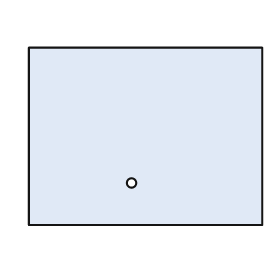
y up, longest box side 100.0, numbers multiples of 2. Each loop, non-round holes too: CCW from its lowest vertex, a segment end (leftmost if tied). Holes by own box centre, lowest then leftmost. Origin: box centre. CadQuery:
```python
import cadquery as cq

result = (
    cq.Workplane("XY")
    .moveTo(-50.0, -38.0)
    .lineTo(50.0, -38.0)
    .lineTo(50.0, 38.0)
    .lineTo(-50.0, 38.0)
    .close()
    .moveTo(-6.0, -20.0)
    .circle(2.0)
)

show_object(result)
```